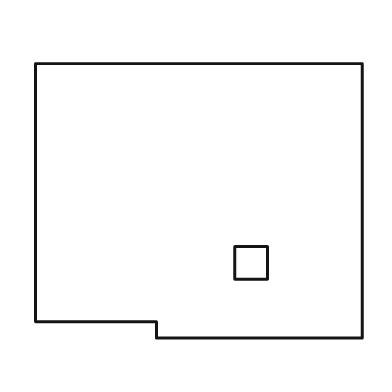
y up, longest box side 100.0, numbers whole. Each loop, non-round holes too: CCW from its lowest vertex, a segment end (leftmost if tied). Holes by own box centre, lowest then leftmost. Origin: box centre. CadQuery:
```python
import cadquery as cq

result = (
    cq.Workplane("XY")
    .moveTo(-13.0, -42.0)
    .lineTo(50.0, -42.0)
    .lineTo(50.0, 42.0)
    .lineTo(-50.0, 42.0)
    .lineTo(-50.0, -37.0)
    .lineTo(-13.0, -37.0)
    .close()
    .moveTo(11.0, -24.0)
    .lineTo(21.0, -24.0)
    .lineTo(21.0, -14.0)
    .lineTo(11.0, -14.0)
    .close()
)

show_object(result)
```